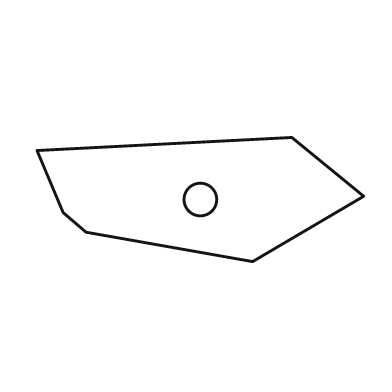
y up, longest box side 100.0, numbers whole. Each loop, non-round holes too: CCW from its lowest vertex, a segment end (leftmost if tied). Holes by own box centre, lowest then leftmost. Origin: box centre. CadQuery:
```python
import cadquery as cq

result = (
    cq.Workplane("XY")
    .moveTo(16.0, -19.0)
    .lineTo(50.0, 1.0)
    .lineTo(28.0, 19.0)
    .lineTo(-50.0, 15.0)
    .lineTo(-42.0, -4.0)
    .lineTo(-35.0, -10.0)
    .close()
    .moveTo(0.0, 0.0)
    .circle(5.0)
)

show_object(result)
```